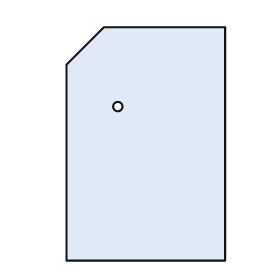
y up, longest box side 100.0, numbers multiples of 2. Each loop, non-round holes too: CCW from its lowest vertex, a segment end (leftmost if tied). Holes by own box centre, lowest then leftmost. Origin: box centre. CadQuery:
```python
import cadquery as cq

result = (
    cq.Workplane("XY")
    .moveTo(-34.0, -50.0)
    .lineTo(34.0, -50.0)
    .lineTo(34.0, 50.0)
    .lineTo(-18.0, 50.0)
    .lineTo(-34.0, 34.0)
    .close()
    .moveTo(-12.0, 16.0)
    .circle(2.0)
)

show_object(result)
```